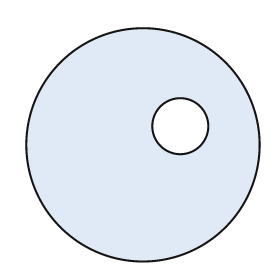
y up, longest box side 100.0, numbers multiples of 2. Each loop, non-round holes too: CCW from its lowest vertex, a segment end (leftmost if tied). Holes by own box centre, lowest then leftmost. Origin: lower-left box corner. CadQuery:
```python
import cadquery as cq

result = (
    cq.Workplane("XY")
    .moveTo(50.0, 50.0)
    .circle(50.0)
    .moveTo(66.0, 58.0)
    .circle(12.0)
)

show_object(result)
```